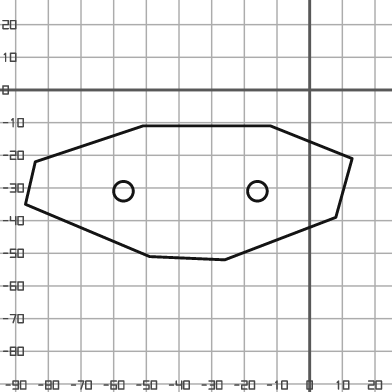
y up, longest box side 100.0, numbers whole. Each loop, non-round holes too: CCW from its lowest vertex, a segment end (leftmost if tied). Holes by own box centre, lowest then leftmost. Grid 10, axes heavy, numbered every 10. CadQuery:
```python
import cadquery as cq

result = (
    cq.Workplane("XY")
    .moveTo(-26.0, -52.0)
    .lineTo(8.0, -39.0)
    .lineTo(13.0, -21.0)
    .lineTo(-12.0, -11.0)
    .lineTo(-51.0, -11.0)
    .lineTo(-84.0, -22.0)
    .lineTo(-87.0, -35.0)
    .lineTo(-49.0, -51.0)
    .close()
    .moveTo(-57.0, -31.0)
    .circle(3.0)
    .moveTo(-16.0, -31.0)
    .circle(3.0)
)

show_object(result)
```